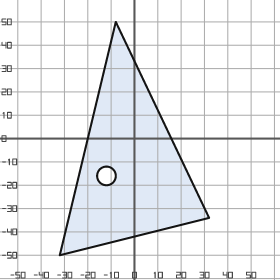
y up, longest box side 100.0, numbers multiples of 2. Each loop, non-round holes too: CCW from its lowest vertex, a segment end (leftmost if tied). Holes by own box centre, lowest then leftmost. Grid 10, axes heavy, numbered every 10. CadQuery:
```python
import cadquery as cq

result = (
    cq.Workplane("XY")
    .moveTo(-32.0, -50.0)
    .lineTo(32.0, -34.0)
    .lineTo(-8.0, 50.0)
    .close()
    .moveTo(-12.0, -16.0)
    .circle(4.0)
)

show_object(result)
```